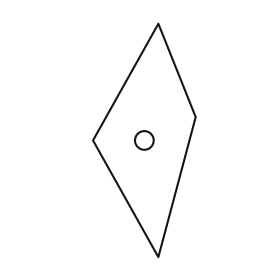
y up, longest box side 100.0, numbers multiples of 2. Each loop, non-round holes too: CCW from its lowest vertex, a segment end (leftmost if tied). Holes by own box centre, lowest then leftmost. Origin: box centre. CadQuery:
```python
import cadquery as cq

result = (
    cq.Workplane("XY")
    .moveTo(6.0, -50.0)
    .lineTo(22.0, 10.0)
    .lineTo(6.0, 50.0)
    .lineTo(-22.0, 0.0)
    .close()
    .moveTo(0.0, 0.0)
    .circle(4.0)
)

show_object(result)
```